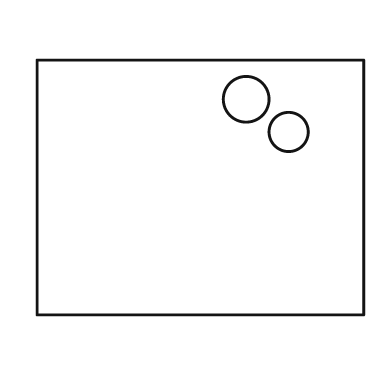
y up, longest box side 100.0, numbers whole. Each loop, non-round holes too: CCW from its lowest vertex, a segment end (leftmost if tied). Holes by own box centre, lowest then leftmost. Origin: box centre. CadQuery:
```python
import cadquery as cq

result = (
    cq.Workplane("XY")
    .moveTo(-50.0, -39.0)
    .lineTo(50.0, -39.0)
    .lineTo(50.0, 39.0)
    .lineTo(-50.0, 39.0)
    .close()
    .moveTo(27.0, 17.0)
    .circle(6.0)
    .moveTo(14.0, 27.0)
    .circle(7.0)
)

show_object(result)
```